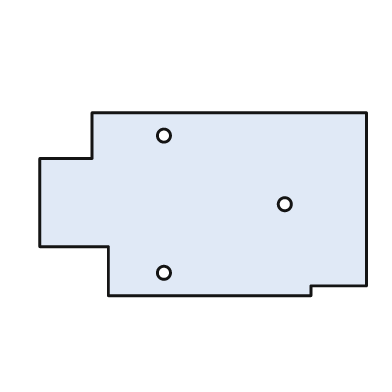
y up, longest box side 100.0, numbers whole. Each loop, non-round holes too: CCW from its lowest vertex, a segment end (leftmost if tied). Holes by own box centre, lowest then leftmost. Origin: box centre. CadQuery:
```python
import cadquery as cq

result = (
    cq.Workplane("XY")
    .moveTo(-29.0, -28.0)
    .lineTo(33.0, -28.0)
    .lineTo(33.0, -25.0)
    .lineTo(50.0, -25.0)
    .lineTo(50.0, 28.0)
    .lineTo(-34.0, 28.0)
    .lineTo(-34.0, 14.0)
    .lineTo(-50.0, 14.0)
    .lineTo(-50.0, -13.0)
    .lineTo(-29.0, -13.0)
    .close()
    .moveTo(-12.0, -21.0)
    .circle(2.0)
    .moveTo(25.0, 0.0)
    .circle(2.0)
    .moveTo(-12.0, 21.0)
    .circle(2.0)
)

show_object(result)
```